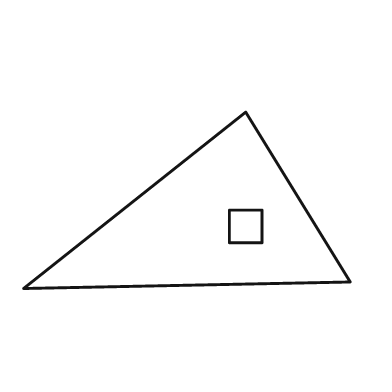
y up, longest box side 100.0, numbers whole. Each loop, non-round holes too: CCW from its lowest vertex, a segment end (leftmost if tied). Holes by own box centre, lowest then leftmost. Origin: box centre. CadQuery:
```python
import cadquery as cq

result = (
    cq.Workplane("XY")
    .moveTo(-50.0, -27.0)
    .lineTo(50.0, -25.0)
    .lineTo(18.0, 27.0)
    .close()
    .moveTo(13.0, -13.0)
    .lineTo(23.0, -13.0)
    .lineTo(23.0, -3.0)
    .lineTo(13.0, -3.0)
    .close()
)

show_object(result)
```